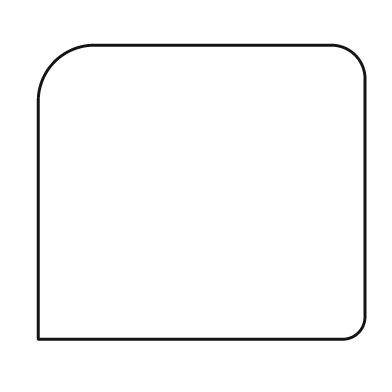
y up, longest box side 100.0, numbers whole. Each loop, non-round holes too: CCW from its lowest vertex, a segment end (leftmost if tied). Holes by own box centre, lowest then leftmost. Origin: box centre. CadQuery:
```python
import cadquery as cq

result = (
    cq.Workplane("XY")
    .moveTo(-50.0, -45.0)
    .lineTo(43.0, -45.0)
    .threePointArc((48.0, -43.0), (50.0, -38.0))
    .lineTo(50.0, 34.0)
    .threePointArc((47.0, 42.0), (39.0, 45.0))
    .lineTo(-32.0, 45.0)
    .threePointArc((-45.0, 40.0), (-50.0, 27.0))
    .close()
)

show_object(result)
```